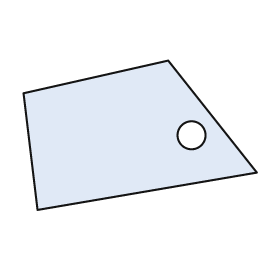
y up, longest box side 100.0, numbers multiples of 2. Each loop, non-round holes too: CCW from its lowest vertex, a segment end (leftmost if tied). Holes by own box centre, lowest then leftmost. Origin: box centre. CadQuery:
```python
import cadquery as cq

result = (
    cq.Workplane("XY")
    .moveTo(-44.0, -32.0)
    .lineTo(50.0, -16.0)
    .lineTo(12.0, 32.0)
    .lineTo(-50.0, 18.0)
    .close()
    .moveTo(22.0, 0.0)
    .circle(6.0)
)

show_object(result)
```